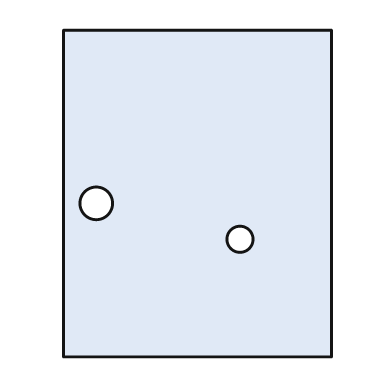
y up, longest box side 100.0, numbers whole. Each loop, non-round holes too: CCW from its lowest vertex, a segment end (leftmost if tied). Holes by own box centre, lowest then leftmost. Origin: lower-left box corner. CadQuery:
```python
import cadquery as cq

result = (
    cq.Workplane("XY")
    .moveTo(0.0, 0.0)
    .lineTo(82.0, 0.0)
    .lineTo(82.0, 100.0)
    .lineTo(0.0, 100.0)
    .close()
    .moveTo(54.0, 36.0)
    .circle(4.0)
    .moveTo(10.0, 47.0)
    .circle(5.0)
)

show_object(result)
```